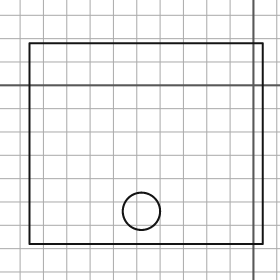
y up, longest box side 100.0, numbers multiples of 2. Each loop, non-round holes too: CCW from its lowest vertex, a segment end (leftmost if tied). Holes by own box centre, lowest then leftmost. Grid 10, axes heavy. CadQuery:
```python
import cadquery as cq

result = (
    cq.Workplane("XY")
    .moveTo(-96.0, -68.0)
    .lineTo(4.0, -68.0)
    .lineTo(4.0, 18.0)
    .lineTo(-96.0, 18.0)
    .close()
    .moveTo(-48.0, -54.0)
    .circle(8.0)
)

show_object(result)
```